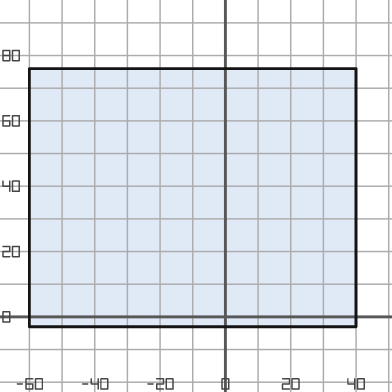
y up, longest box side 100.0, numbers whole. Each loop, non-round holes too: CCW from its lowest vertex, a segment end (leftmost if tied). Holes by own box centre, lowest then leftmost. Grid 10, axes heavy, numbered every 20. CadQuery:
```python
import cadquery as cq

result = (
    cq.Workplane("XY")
    .moveTo(-60.0, -3.0)
    .lineTo(40.0, -3.0)
    .lineTo(40.0, 76.0)
    .lineTo(-60.0, 76.0)
    .close()
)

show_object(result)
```